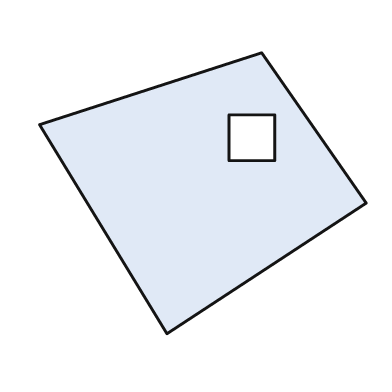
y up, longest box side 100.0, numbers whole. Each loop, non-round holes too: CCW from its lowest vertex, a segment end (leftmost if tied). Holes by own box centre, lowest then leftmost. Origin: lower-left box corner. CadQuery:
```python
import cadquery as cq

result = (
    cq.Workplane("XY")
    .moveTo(39.0, 0.0)
    .lineTo(100.0, 40.0)
    .lineTo(68.0, 86.0)
    .lineTo(0.0, 64.0)
    .close()
    .moveTo(58.0, 53.0)
    .lineTo(72.0, 53.0)
    .lineTo(72.0, 67.0)
    .lineTo(58.0, 67.0)
    .close()
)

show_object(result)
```